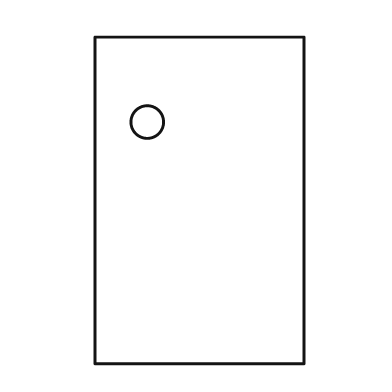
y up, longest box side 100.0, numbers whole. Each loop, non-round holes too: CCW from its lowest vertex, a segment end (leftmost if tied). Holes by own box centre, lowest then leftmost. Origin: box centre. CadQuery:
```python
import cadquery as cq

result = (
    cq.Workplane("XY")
    .moveTo(-32.0, -50.0)
    .lineTo(32.0, -50.0)
    .lineTo(32.0, 50.0)
    .lineTo(-32.0, 50.0)
    .close()
    .moveTo(-16.0, 24.0)
    .circle(5.0)
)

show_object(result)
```